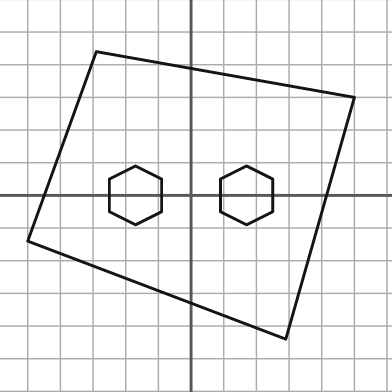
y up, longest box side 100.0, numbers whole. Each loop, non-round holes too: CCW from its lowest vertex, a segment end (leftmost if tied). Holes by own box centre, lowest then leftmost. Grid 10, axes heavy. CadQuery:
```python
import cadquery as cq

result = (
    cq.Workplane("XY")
    .moveTo(29.0, -44.0)
    .lineTo(50.0, 30.0)
    .lineTo(-29.0, 44.0)
    .lineTo(-50.0, -14.0)
    .close()
    .moveTo(-17.0, -9.0)
    .lineTo(-9.0, -5.0)
    .lineTo(-9.0, 5.0)
    .lineTo(-17.0, 9.0)
    .lineTo(-25.0, 5.0)
    .lineTo(-25.0, -5.0)
    .close()
    .moveTo(17.0, -9.0)
    .lineTo(25.0, -5.0)
    .lineTo(25.0, 5.0)
    .lineTo(17.0, 9.0)
    .lineTo(9.0, 5.0)
    .lineTo(9.0, -5.0)
    .close()
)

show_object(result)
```